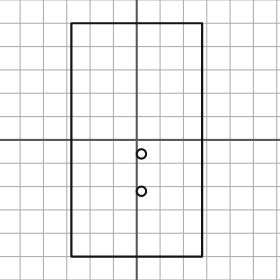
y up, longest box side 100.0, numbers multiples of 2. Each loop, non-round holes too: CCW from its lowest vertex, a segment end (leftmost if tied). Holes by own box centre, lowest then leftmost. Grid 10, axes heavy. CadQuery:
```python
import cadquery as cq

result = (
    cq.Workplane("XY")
    .moveTo(-28.0, -50.0)
    .lineTo(28.0, -50.0)
    .lineTo(28.0, 50.0)
    .lineTo(-28.0, 50.0)
    .close()
    .moveTo(2.0, -22.0)
    .circle(2.0)
    .moveTo(2.0, -6.0)
    .circle(2.0)
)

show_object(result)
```